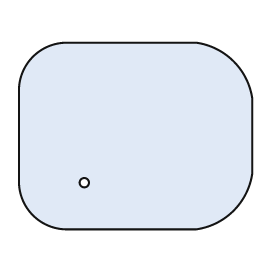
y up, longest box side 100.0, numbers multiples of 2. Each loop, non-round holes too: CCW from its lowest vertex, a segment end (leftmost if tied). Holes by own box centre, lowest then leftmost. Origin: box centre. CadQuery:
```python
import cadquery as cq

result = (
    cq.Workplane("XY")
    .moveTo(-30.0, -40.0)
    .lineTo(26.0, -40.0)
    .threePointArc((42.0, -32.0), (50.0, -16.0))
    .lineTo(50.0, 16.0)
    .threePointArc((42.0, 32.0), (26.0, 40.0))
    .lineTo(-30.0, 40.0)
    .threePointArc((-44.0, 34.0), (-50.0, 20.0))
    .lineTo(-50.0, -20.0)
    .threePointArc((-44.0, -34.0), (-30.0, -40.0))
    .close()
    .moveTo(-22.0, -20.0)
    .circle(2.0)
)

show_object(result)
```